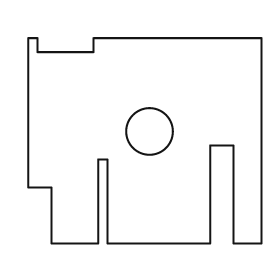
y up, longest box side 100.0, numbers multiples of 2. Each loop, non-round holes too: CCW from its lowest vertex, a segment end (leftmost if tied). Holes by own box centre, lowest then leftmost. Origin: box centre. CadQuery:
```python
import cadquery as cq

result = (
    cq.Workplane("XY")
    .moveTo(-40.0, -44.0)
    .lineTo(-20.0, -44.0)
    .lineTo(-20.0, -8.0)
    .lineTo(-16.0, -8.0)
    .lineTo(-16.0, -44.0)
    .lineTo(28.0, -44.0)
    .lineTo(28.0, -2.0)
    .lineTo(38.0, -2.0)
    .lineTo(38.0, -44.0)
    .lineTo(50.0, -44.0)
    .lineTo(50.0, 44.0)
    .lineTo(-22.0, 44.0)
    .lineTo(-22.0, 38.0)
    .lineTo(-46.0, 38.0)
    .lineTo(-46.0, 44.0)
    .lineTo(-50.0, 44.0)
    .lineTo(-50.0, -20.0)
    .lineTo(-40.0, -20.0)
    .close()
    .moveTo(2.0, 4.0)
    .circle(10.0)
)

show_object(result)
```